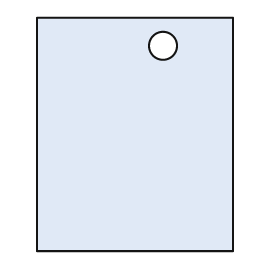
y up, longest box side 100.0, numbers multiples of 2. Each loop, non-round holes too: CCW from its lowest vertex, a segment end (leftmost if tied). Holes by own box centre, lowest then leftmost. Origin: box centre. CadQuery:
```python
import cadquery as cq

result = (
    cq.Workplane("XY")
    .moveTo(-42.0, -50.0)
    .lineTo(42.0, -50.0)
    .lineTo(42.0, 50.0)
    .lineTo(-42.0, 50.0)
    .close()
    .moveTo(12.0, 38.0)
    .circle(6.0)
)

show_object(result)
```